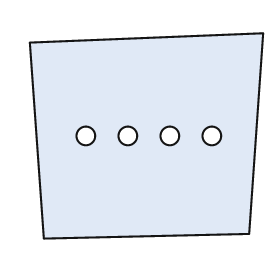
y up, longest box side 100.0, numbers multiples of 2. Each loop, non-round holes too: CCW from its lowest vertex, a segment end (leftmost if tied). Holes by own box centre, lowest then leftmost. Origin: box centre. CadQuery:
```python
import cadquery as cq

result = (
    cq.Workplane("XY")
    .moveTo(-44.0, -44.0)
    .lineTo(44.0, -42.0)
    .lineTo(50.0, 44.0)
    .lineTo(-50.0, 40.0)
    .close()
    .moveTo(-26.0, 0.0)
    .circle(4.0)
    .moveTo(-8.0, 0.0)
    .circle(4.0)
    .moveTo(10.0, 0.0)
    .circle(4.0)
    .moveTo(28.0, 0.0)
    .circle(4.0)
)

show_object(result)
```